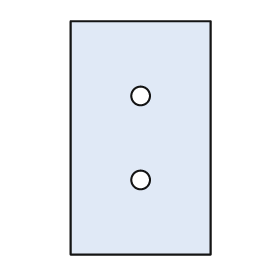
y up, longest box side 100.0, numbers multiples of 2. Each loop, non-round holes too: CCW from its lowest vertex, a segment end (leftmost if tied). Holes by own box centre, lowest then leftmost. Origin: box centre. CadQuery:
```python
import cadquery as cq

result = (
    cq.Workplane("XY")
    .moveTo(-30.0, -50.0)
    .lineTo(30.0, -50.0)
    .lineTo(30.0, 50.0)
    .lineTo(-30.0, 50.0)
    .close()
    .moveTo(0.0, -18.0)
    .circle(4.0)
    .moveTo(0.0, 18.0)
    .circle(4.0)
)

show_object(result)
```